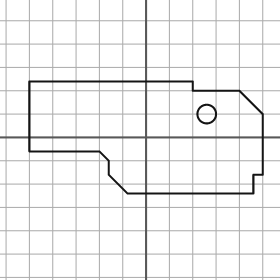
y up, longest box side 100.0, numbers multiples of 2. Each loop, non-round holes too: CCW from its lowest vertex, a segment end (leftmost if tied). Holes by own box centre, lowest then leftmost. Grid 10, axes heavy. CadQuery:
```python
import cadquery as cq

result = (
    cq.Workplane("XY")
    .moveTo(-8.0, -24.0)
    .lineTo(46.0, -24.0)
    .lineTo(46.0, -16.0)
    .lineTo(50.0, -16.0)
    .lineTo(50.0, 10.0)
    .lineTo(40.0, 20.0)
    .lineTo(20.0, 20.0)
    .lineTo(20.0, 24.0)
    .lineTo(-50.0, 24.0)
    .lineTo(-50.0, -6.0)
    .lineTo(-20.0, -6.0)
    .lineTo(-16.0, -10.0)
    .lineTo(-16.0, -16.0)
    .close()
    .moveTo(26.0, 10.0)
    .circle(4.0)
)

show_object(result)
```